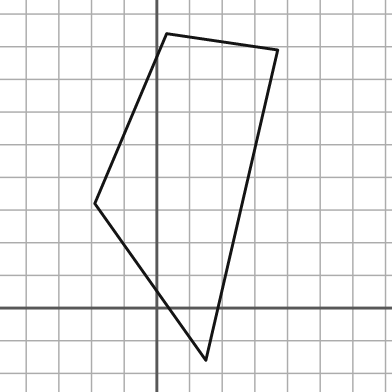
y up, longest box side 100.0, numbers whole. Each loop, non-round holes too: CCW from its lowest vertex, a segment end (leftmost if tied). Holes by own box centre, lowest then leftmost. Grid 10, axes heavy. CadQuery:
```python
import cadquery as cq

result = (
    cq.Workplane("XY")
    .moveTo(15.0, -16.0)
    .lineTo(37.0, 79.0)
    .lineTo(3.0, 84.0)
    .lineTo(-19.0, 32.0)
    .close()
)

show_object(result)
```